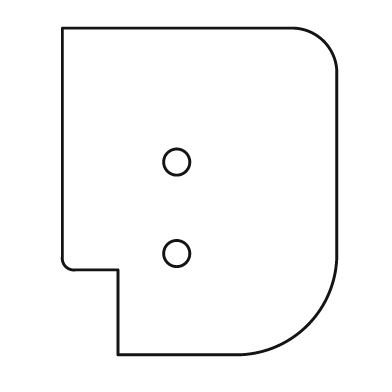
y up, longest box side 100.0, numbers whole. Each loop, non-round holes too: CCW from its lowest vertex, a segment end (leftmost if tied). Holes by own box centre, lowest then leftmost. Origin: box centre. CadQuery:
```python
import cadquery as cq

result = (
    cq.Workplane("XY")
    .moveTo(-25.0, -50.0)
    .lineTo(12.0, -50.0)
    .threePointArc((33.0, -41.0), (42.0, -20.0))
    .lineTo(42.0, 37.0)
    .threePointArc((38.0, 46.0), (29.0, 50.0))
    .lineTo(-42.0, 50.0)
    .lineTo(-42.0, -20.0)
    .threePointArc((-41.0, -23.0), (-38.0, -24.0))
    .lineTo(-25.0, -24.0)
    .close()
    .moveTo(-7.0, -19.0)
    .circle(4.0)
    .moveTo(-7.0, 9.0)
    .circle(4.0)
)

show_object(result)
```